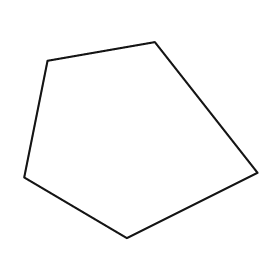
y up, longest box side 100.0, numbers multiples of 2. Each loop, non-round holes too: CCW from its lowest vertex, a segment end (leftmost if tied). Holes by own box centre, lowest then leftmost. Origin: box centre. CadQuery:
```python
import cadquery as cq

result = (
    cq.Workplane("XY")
    .moveTo(-6.0, -42.0)
    .lineTo(50.0, -14.0)
    .lineTo(6.0, 42.0)
    .lineTo(-40.0, 34.0)
    .lineTo(-50.0, -16.0)
    .close()
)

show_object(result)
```